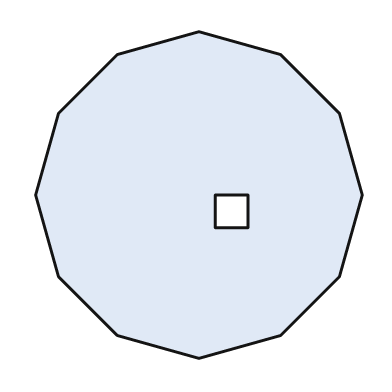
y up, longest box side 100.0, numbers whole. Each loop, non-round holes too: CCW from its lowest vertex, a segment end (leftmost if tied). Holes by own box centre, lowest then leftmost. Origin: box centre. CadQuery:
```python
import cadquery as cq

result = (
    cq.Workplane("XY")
    .moveTo(0.0, -50.0)
    .lineTo(25.0, -43.0)
    .lineTo(43.0, -25.0)
    .lineTo(50.0, 0.0)
    .lineTo(43.0, 25.0)
    .lineTo(25.0, 43.0)
    .lineTo(0.0, 50.0)
    .lineTo(-25.0, 43.0)
    .lineTo(-43.0, 25.0)
    .lineTo(-50.0, 0.0)
    .lineTo(-43.0, -25.0)
    .lineTo(-25.0, -43.0)
    .close()
    .moveTo(5.0, -10.0)
    .lineTo(15.0, -10.0)
    .lineTo(15.0, 0.0)
    .lineTo(5.0, 0.0)
    .close()
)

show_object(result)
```